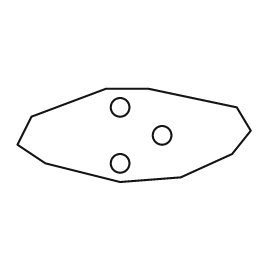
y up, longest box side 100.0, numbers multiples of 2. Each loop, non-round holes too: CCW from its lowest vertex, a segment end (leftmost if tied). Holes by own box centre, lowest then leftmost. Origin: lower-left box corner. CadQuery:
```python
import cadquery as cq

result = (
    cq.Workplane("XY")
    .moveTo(44.0, 0.0)
    .lineTo(70.0, 2.0)
    .lineTo(92.0, 12.0)
    .lineTo(100.0, 22.0)
    .lineTo(94.0, 32.0)
    .lineTo(56.0, 40.0)
    .lineTo(38.0, 40.0)
    .lineTo(6.0, 28.0)
    .lineTo(0.0, 16.0)
    .lineTo(12.0, 8.0)
    .close()
    .moveTo(44.0, 8.0)
    .circle(4.0)
    .moveTo(62.0, 20.0)
    .circle(4.0)
    .moveTo(44.0, 32.0)
    .circle(4.0)
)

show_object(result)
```